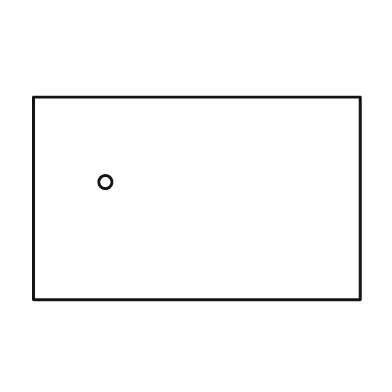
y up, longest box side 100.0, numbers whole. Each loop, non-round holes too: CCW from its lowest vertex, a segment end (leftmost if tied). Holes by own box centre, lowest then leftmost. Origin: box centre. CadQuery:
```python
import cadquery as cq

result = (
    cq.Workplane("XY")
    .moveTo(-50.0, -31.0)
    .lineTo(50.0, -31.0)
    .lineTo(50.0, 31.0)
    .lineTo(-50.0, 31.0)
    .close()
    .moveTo(-28.0, 5.0)
    .circle(2.0)
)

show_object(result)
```